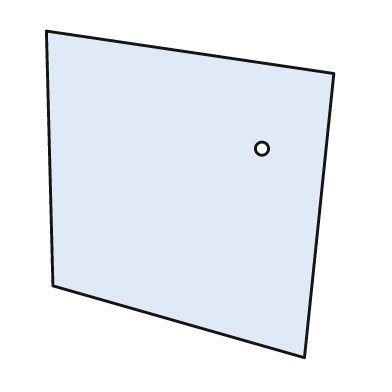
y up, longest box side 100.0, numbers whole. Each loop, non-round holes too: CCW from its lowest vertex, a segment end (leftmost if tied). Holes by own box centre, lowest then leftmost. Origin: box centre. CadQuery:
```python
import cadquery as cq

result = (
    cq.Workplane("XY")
    .moveTo(35.0, -50.0)
    .lineTo(44.0, 37.0)
    .lineTo(-44.0, 50.0)
    .lineTo(-42.0, -28.0)
    .close()
    .moveTo(22.0, 14.0)
    .circle(2.0)
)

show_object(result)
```